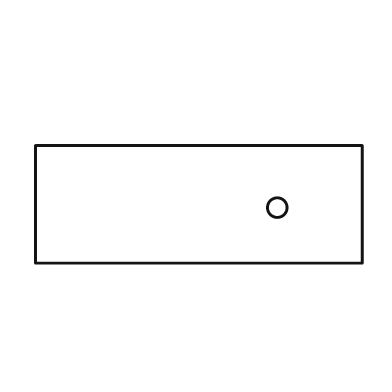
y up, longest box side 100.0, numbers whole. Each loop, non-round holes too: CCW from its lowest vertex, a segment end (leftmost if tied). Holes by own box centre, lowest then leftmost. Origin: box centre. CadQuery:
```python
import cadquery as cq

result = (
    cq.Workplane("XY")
    .moveTo(-50.0, -18.0)
    .lineTo(50.0, -18.0)
    .lineTo(50.0, 18.0)
    .lineTo(-50.0, 18.0)
    .close()
    .moveTo(24.0, -1.0)
    .circle(3.0)
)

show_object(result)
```